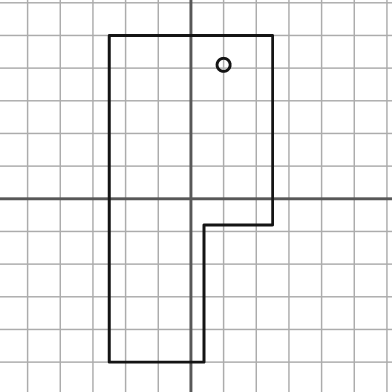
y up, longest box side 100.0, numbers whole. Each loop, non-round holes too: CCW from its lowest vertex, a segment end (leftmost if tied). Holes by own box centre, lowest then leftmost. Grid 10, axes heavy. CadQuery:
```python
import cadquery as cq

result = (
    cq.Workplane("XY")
    .moveTo(-25.0, -50.0)
    .lineTo(4.0, -50.0)
    .lineTo(4.0, -8.0)
    .lineTo(25.0, -8.0)
    .lineTo(25.0, 50.0)
    .lineTo(-25.0, 50.0)
    .close()
    .moveTo(10.0, 41.0)
    .circle(2.0)
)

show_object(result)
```